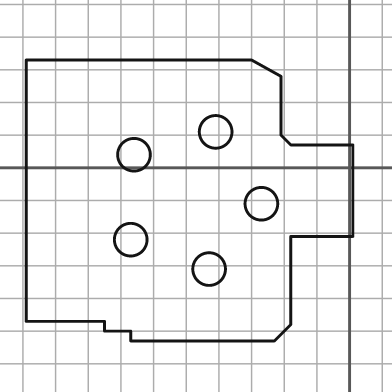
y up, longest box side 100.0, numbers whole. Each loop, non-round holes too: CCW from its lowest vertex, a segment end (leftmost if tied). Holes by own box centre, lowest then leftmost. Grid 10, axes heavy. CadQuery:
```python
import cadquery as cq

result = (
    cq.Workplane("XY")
    .moveTo(-67.0, -53.0)
    .lineTo(-23.0, -53.0)
    .lineTo(-18.0, -48.0)
    .lineTo(-18.0, -21.0)
    .lineTo(1.0, -21.0)
    .lineTo(1.0, 7.0)
    .lineTo(-18.0, 7.0)
    .lineTo(-21.0, 10.0)
    .lineTo(-21.0, 28.0)
    .lineTo(-30.0, 33.0)
    .lineTo(-99.0, 33.0)
    .lineTo(-99.0, -47.0)
    .lineTo(-75.0, -47.0)
    .lineTo(-75.0, -50.0)
    .lineTo(-67.0, -50.0)
    .close()
    .moveTo(-43.0, -31.0)
    .circle(5.0)
    .moveTo(-67.0, -22.0)
    .circle(5.0)
    .moveTo(-27.0, -11.0)
    .circle(5.0)
    .moveTo(-66.0, 4.0)
    .circle(5.0)
    .moveTo(-41.0, 11.0)
    .circle(5.0)
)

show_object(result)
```